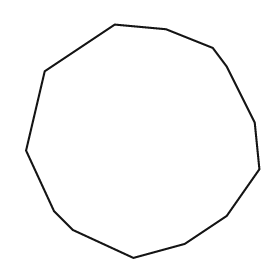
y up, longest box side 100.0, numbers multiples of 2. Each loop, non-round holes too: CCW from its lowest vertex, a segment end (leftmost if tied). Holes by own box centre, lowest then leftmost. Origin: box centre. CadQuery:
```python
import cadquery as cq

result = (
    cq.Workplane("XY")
    .moveTo(-4.0, -50.0)
    .lineTo(18.0, -44.0)
    .lineTo(36.0, -32.0)
    .lineTo(50.0, -12.0)
    .lineTo(48.0, 8.0)
    .lineTo(36.0, 32.0)
    .lineTo(30.0, 40.0)
    .lineTo(10.0, 48.0)
    .lineTo(-12.0, 50.0)
    .lineTo(-42.0, 30.0)
    .lineTo(-50.0, -4.0)
    .lineTo(-38.0, -30.0)
    .lineTo(-30.0, -38.0)
    .close()
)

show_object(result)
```